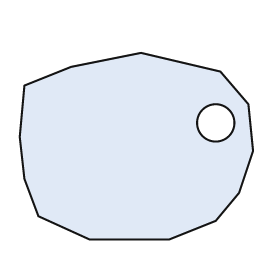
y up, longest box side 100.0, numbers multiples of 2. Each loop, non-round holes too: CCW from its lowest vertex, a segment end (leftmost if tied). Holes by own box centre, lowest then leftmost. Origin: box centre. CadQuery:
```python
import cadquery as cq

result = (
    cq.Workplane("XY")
    .moveTo(-20.0, -40.0)
    .lineTo(14.0, -40.0)
    .lineTo(34.0, -32.0)
    .lineTo(44.0, -20.0)
    .lineTo(50.0, -2.0)
    .lineTo(48.0, 18.0)
    .lineTo(36.0, 32.0)
    .lineTo(2.0, 40.0)
    .lineTo(-28.0, 34.0)
    .lineTo(-48.0, 26.0)
    .lineTo(-50.0, 4.0)
    .lineTo(-48.0, -14.0)
    .lineTo(-42.0, -30.0)
    .close()
    .moveTo(34.0, 10.0)
    .circle(8.0)
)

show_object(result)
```